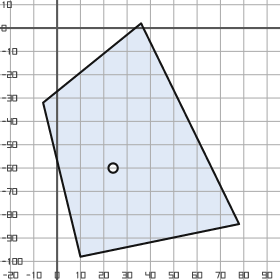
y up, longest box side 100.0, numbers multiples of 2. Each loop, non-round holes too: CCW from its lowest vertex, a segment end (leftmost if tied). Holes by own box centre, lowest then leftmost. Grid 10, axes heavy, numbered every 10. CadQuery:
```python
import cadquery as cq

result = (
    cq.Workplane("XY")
    .moveTo(10.0, -98.0)
    .lineTo(78.0, -84.0)
    .lineTo(36.0, 2.0)
    .lineTo(-6.0, -32.0)
    .close()
    .moveTo(24.0, -60.0)
    .circle(2.0)
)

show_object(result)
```